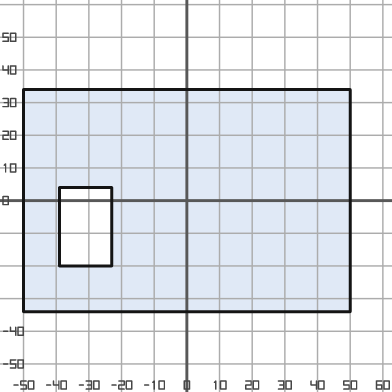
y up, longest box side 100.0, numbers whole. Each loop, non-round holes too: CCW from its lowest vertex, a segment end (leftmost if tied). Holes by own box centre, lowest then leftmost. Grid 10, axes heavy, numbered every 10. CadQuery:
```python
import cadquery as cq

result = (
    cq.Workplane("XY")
    .moveTo(-50.0, -34.0)
    .lineTo(50.0, -34.0)
    .lineTo(50.0, 34.0)
    .lineTo(-50.0, 34.0)
    .close()
    .moveTo(-39.0, -20.0)
    .lineTo(-23.0, -20.0)
    .lineTo(-23.0, 4.0)
    .lineTo(-39.0, 4.0)
    .close()
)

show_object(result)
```